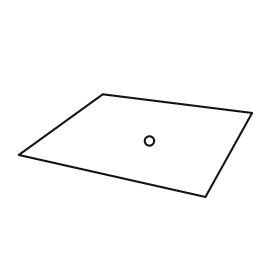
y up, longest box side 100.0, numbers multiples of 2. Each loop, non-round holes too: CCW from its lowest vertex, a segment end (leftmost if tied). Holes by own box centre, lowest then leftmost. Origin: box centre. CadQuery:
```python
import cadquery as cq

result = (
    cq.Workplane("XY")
    .moveTo(30.0, -22.0)
    .lineTo(50.0, 14.0)
    .lineTo(-14.0, 22.0)
    .lineTo(-50.0, -4.0)
    .close()
    .moveTo(6.0, 2.0)
    .circle(2.0)
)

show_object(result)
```